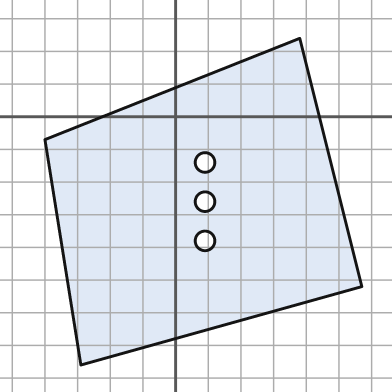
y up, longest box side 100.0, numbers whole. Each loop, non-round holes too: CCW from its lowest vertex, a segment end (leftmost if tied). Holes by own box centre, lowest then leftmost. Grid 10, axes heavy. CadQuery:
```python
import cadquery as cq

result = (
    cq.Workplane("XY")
    .moveTo(-29.0, -76.0)
    .lineTo(57.0, -52.0)
    .lineTo(38.0, 24.0)
    .lineTo(-40.0, -7.0)
    .close()
    .moveTo(9.0, -38.0)
    .circle(3.0)
    .moveTo(9.0, -26.0)
    .circle(3.0)
    .moveTo(9.0, -14.0)
    .circle(3.0)
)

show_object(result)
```